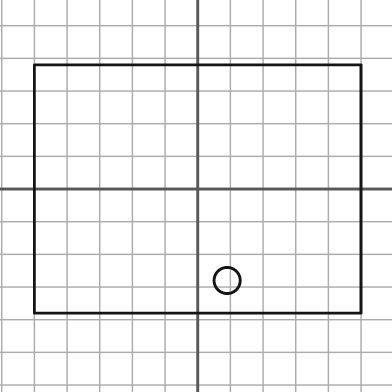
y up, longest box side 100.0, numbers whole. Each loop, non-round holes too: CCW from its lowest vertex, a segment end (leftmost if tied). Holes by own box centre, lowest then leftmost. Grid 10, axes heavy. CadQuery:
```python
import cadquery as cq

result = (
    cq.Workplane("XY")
    .moveTo(-50.0, -38.0)
    .lineTo(50.0, -38.0)
    .lineTo(50.0, 38.0)
    .lineTo(-50.0, 38.0)
    .close()
    .moveTo(9.0, -28.0)
    .circle(4.0)
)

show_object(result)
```